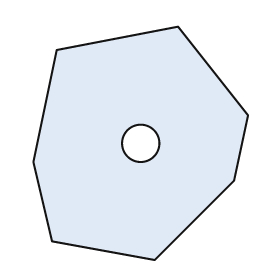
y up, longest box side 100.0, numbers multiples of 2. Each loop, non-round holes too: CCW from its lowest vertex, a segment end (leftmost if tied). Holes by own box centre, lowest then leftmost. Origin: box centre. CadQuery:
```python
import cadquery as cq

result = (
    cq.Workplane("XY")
    .moveTo(6.0, -50.0)
    .lineTo(40.0, -16.0)
    .lineTo(46.0, 12.0)
    .lineTo(16.0, 50.0)
    .lineTo(-36.0, 40.0)
    .lineTo(-46.0, -8.0)
    .lineTo(-38.0, -42.0)
    .close()
    .moveTo(0.0, 0.0)
    .circle(8.0)
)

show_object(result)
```